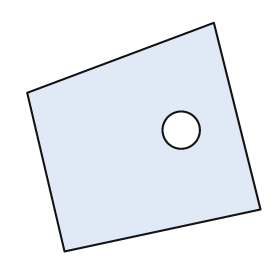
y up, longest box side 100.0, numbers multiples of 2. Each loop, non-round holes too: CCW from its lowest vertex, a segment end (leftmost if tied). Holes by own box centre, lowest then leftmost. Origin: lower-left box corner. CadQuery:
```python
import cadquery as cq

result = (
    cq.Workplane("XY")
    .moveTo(16.0, 0.0)
    .lineTo(100.0, 18.0)
    .lineTo(80.0, 98.0)
    .lineTo(0.0, 68.0)
    .close()
    .moveTo(66.0, 52.0)
    .circle(8.0)
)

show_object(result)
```